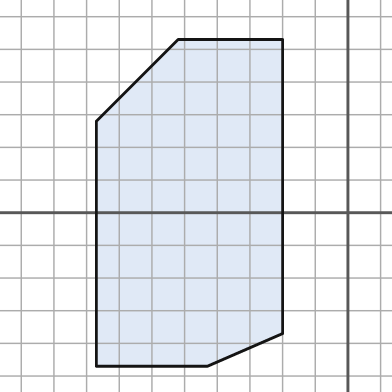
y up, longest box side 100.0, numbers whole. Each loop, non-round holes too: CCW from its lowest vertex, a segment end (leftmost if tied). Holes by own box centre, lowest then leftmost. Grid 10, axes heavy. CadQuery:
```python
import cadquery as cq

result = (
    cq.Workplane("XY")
    .moveTo(-77.0, -47.0)
    .lineTo(-43.0, -47.0)
    .lineTo(-20.0, -37.0)
    .lineTo(-20.0, 53.0)
    .lineTo(-52.0, 53.0)
    .lineTo(-77.0, 28.0)
    .close()
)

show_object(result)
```